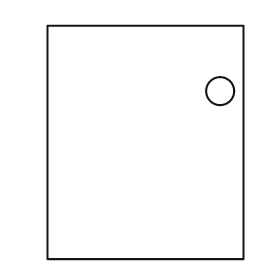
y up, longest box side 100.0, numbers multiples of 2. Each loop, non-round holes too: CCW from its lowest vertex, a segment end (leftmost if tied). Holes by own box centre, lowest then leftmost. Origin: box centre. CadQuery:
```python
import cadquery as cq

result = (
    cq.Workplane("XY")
    .moveTo(-42.0, -50.0)
    .lineTo(42.0, -50.0)
    .lineTo(42.0, 50.0)
    .lineTo(-42.0, 50.0)
    .close()
    .moveTo(32.0, 22.0)
    .circle(6.0)
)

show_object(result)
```